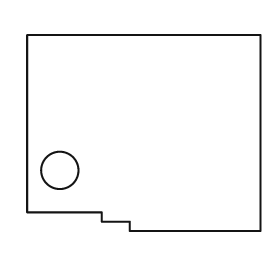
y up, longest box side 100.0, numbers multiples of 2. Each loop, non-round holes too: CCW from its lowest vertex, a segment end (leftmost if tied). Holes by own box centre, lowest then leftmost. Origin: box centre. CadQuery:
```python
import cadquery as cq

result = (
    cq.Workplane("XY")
    .moveTo(-6.0, -42.0)
    .lineTo(50.0, -42.0)
    .lineTo(50.0, 42.0)
    .lineTo(-50.0, 42.0)
    .lineTo(-50.0, -34.0)
    .lineTo(-18.0, -34.0)
    .lineTo(-18.0, -38.0)
    .lineTo(-6.0, -38.0)
    .close()
    .moveTo(-36.0, -16.0)
    .circle(8.0)
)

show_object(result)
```